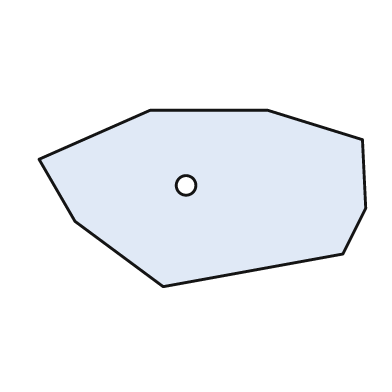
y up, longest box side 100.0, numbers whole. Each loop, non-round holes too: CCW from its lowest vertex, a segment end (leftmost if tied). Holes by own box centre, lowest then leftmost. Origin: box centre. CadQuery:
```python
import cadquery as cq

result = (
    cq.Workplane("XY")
    .moveTo(-12.0, -27.0)
    .lineTo(43.0, -17.0)
    .lineTo(50.0, -3.0)
    .lineTo(49.0, 18.0)
    .lineTo(20.0, 27.0)
    .lineTo(-16.0, 27.0)
    .lineTo(-50.0, 12.0)
    .lineTo(-39.0, -7.0)
    .close()
    .moveTo(-5.0, 4.0)
    .circle(3.0)
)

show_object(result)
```